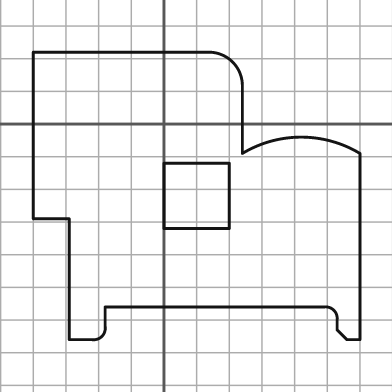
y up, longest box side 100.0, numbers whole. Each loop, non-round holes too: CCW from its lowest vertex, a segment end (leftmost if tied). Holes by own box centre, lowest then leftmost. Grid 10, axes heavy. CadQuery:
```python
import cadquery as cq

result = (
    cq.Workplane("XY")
    .moveTo(-29.0, -66.0)
    .lineTo(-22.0, -66.0)
    .threePointArc((-19.0, -65.0), (-18.0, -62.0))
    .lineTo(-18.0, -56.0)
    .lineTo(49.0, -56.0)
    .threePointArc((52.0, -57.0), (53.0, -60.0))
    .lineTo(53.0, -63.0)
    .lineTo(56.0, -66.0)
    .lineTo(60.0, -66.0)
    .lineTo(60.0, -9.0)
    .threePointArc((42.0, -4.0), (24.0, -9.0))
    .lineTo(24.0, 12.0)
    .threePointArc((21.0, 19.0), (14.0, 22.0))
    .lineTo(-40.0, 22.0)
    .lineTo(-40.0, -29.0)
    .lineTo(-29.0, -29.0)
    .close()
    .moveTo(0.0, -32.0)
    .lineTo(20.0, -32.0)
    .lineTo(20.0, -12.0)
    .lineTo(0.0, -12.0)
    .close()
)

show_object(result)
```